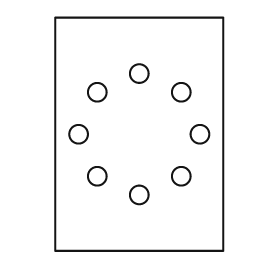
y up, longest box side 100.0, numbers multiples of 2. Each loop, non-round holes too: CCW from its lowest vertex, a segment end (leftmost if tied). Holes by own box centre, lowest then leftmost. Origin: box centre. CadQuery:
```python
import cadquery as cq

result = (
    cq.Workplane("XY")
    .moveTo(-36.0, -50.0)
    .lineTo(36.0, -50.0)
    .lineTo(36.0, 50.0)
    .lineTo(-36.0, 50.0)
    .close()
    .moveTo(0.0, -26.0)
    .circle(4.0)
    .moveTo(-18.0, -18.0)
    .circle(4.0)
    .moveTo(18.0, -18.0)
    .circle(4.0)
    .moveTo(-26.0, 0.0)
    .circle(4.0)
    .moveTo(26.0, 0.0)
    .circle(4.0)
    .moveTo(-18.0, 18.0)
    .circle(4.0)
    .moveTo(18.0, 18.0)
    .circle(4.0)
    .moveTo(0.0, 26.0)
    .circle(4.0)
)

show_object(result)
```